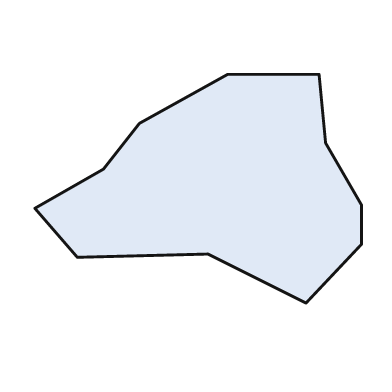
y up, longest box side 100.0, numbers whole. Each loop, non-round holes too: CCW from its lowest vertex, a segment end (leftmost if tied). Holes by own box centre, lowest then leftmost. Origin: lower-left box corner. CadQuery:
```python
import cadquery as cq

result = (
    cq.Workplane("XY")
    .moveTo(83.0, 0.0)
    .lineTo(100.0, 18.0)
    .lineTo(100.0, 30.0)
    .lineTo(89.0, 49.0)
    .lineTo(87.0, 70.0)
    .lineTo(59.0, 70.0)
    .lineTo(32.0, 55.0)
    .lineTo(21.0, 41.0)
    .lineTo(0.0, 29.0)
    .lineTo(13.0, 14.0)
    .lineTo(53.0, 15.0)
    .close()
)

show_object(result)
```